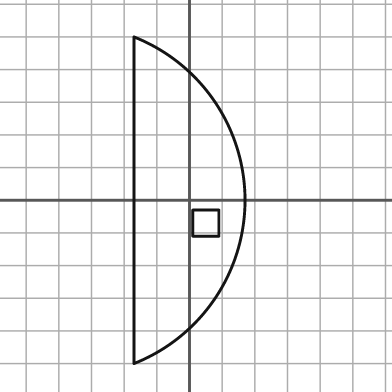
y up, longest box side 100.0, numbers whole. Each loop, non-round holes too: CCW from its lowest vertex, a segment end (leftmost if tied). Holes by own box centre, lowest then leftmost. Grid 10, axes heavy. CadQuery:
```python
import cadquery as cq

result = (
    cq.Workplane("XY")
    .moveTo(-17.0, -50.0)
    .threePointArc((17.0, 0.0), (-17.0, 50.0))
    .close()
    .moveTo(1.0, -11.0)
    .lineTo(9.0, -11.0)
    .lineTo(9.0, -3.0)
    .lineTo(1.0, -3.0)
    .close()
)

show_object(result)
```